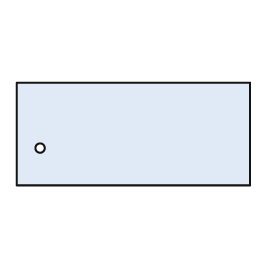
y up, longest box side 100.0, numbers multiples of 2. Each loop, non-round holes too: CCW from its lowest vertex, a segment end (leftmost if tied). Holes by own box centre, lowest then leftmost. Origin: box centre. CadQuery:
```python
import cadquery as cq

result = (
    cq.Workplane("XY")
    .moveTo(-50.0, -22.0)
    .lineTo(50.0, -22.0)
    .lineTo(50.0, 22.0)
    .lineTo(-50.0, 22.0)
    .close()
    .moveTo(-40.0, -6.0)
    .circle(2.0)
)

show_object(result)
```